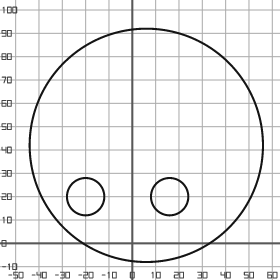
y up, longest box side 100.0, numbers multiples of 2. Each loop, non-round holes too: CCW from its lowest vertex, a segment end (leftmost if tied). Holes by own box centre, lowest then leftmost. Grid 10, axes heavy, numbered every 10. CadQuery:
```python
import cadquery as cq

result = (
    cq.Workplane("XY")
    .moveTo(6.0, 42.0)
    .circle(50.0)
    .moveTo(-20.0, 20.0)
    .circle(8.0)
    .moveTo(16.0, 20.0)
    .circle(8.0)
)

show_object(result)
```